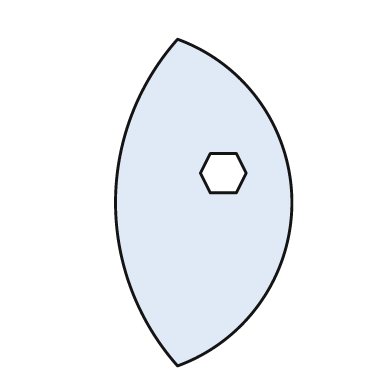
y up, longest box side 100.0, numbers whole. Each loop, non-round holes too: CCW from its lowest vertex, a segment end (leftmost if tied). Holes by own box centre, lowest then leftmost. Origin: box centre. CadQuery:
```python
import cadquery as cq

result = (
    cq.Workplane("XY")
    .moveTo(-8.0, -50.0)
    .threePointArc((27.0, 0.0), (-8.0, 50.0))
    .threePointArc((-27.0, 0.0), (-8.0, -50.0))
    .close()
    .moveTo(2.0, 3.0)
    .lineTo(10.0, 3.0)
    .lineTo(13.0, 9.0)
    .lineTo(10.0, 15.0)
    .lineTo(2.0, 15.0)
    .lineTo(-1.0, 9.0)
    .close()
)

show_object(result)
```